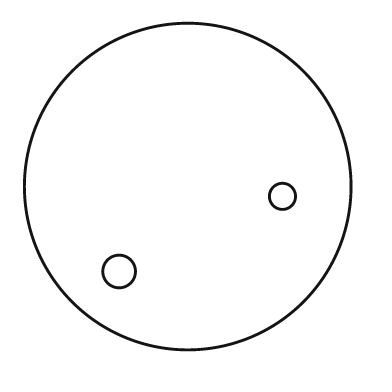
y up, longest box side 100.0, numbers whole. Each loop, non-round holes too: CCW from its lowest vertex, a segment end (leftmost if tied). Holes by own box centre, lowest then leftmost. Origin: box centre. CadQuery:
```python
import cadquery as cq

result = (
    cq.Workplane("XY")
    .moveTo(0.0, 0.0)
    .circle(50.0)
    .moveTo(-21.0, -26.0)
    .circle(5.0)
    .moveTo(29.0, -3.0)
    .circle(4.0)
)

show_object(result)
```